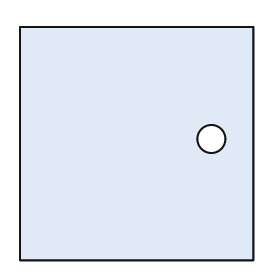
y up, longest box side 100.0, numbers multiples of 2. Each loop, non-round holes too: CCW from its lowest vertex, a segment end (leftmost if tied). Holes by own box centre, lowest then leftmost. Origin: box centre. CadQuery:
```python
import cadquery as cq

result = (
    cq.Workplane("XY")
    .moveTo(-50.0, -50.0)
    .lineTo(50.0, -50.0)
    .lineTo(50.0, 50.0)
    .lineTo(-50.0, 50.0)
    .close()
    .moveTo(32.0, 2.0)
    .circle(6.0)
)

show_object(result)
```